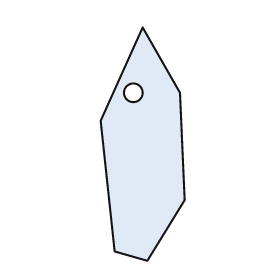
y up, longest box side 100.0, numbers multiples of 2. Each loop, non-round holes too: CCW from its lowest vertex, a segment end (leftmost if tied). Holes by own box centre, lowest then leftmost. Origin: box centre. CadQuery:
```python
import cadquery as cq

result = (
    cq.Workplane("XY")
    .moveTo(2.0, -50.0)
    .lineTo(18.0, -24.0)
    .lineTo(16.0, 22.0)
    .lineTo(0.0, 50.0)
    .lineTo(-18.0, 10.0)
    .lineTo(-12.0, -46.0)
    .close()
    .moveTo(-4.0, 22.0)
    .circle(4.0)
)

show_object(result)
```